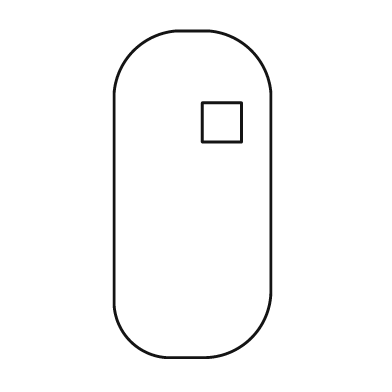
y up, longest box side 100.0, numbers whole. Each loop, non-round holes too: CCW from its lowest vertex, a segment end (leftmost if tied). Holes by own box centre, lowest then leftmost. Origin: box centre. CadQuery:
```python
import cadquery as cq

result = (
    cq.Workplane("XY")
    .moveTo(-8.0, -50.0)
    .lineTo(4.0, -50.0)
    .threePointArc((18.0, -44.0), (24.0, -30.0))
    .lineTo(24.0, 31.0)
    .threePointArc((18.0, 44.0), (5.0, 50.0))
    .lineTo(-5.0, 50.0)
    .threePointArc((-18.0, 44.0), (-24.0, 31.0))
    .lineTo(-24.0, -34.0)
    .threePointArc((-19.0, -45.0), (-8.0, -50.0))
    .close()
    .moveTo(3.0, 16.0)
    .lineTo(15.0, 16.0)
    .lineTo(15.0, 28.0)
    .lineTo(3.0, 28.0)
    .close()
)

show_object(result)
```